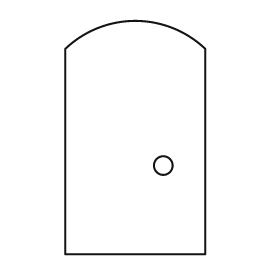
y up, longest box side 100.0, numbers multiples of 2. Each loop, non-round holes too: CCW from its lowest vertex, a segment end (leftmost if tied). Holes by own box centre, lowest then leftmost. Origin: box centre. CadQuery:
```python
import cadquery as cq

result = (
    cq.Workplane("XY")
    .moveTo(-30.0, -50.0)
    .lineTo(30.0, -50.0)
    .lineTo(30.0, 38.0)
    .threePointArc((0.0, 50.0), (-30.0, 38.0))
    .close()
    .moveTo(12.0, -12.0)
    .circle(4.0)
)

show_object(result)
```